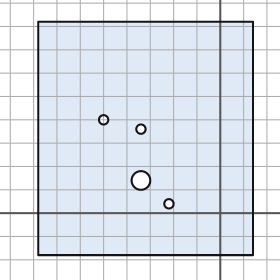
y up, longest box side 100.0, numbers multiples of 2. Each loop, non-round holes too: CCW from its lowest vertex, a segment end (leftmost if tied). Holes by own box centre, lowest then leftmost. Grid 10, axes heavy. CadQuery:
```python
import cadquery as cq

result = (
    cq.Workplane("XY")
    .moveTo(-78.0, -18.0)
    .lineTo(14.0, -18.0)
    .lineTo(14.0, 82.0)
    .lineTo(-78.0, 82.0)
    .close()
    .moveTo(-22.0, 4.0)
    .circle(2.0)
    .moveTo(-34.0, 14.0)
    .circle(4.0)
    .moveTo(-34.0, 36.0)
    .circle(2.0)
    .moveTo(-50.0, 40.0)
    .circle(2.0)
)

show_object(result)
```